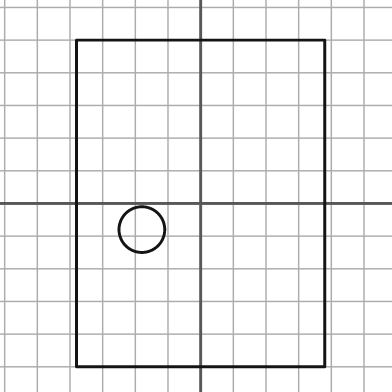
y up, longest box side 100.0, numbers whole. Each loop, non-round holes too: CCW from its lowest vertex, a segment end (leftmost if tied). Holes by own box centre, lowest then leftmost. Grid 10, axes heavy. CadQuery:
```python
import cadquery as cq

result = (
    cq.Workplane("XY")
    .moveTo(-38.0, -50.0)
    .lineTo(38.0, -50.0)
    .lineTo(38.0, 50.0)
    .lineTo(-38.0, 50.0)
    .close()
    .moveTo(-18.0, -8.0)
    .circle(7.0)
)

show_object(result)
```